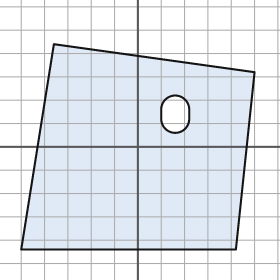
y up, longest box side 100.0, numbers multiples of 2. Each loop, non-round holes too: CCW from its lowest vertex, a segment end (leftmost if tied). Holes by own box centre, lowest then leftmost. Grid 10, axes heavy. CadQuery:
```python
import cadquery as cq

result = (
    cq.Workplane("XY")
    .moveTo(-50.0, -44.0)
    .lineTo(42.0, -44.0)
    .lineTo(50.0, 32.0)
    .lineTo(-36.0, 44.0)
    .close()
    .moveTo(10.0, 12.0)
    .threePointArc((16.0, 6.0), (22.0, 12.0))
    .lineTo(22.0, 16.0)
    .threePointArc((16.0, 22.0), (10.0, 16.0))
    .close()
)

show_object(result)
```